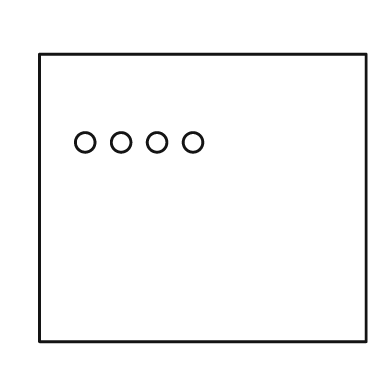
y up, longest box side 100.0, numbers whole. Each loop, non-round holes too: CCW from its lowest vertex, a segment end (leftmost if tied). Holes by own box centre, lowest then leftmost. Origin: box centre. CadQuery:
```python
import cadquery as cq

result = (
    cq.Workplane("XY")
    .moveTo(-50.0, -44.0)
    .lineTo(50.0, -44.0)
    .lineTo(50.0, 44.0)
    .lineTo(-50.0, 44.0)
    .close()
    .moveTo(-36.0, 17.0)
    .circle(3.0)
    .moveTo(-25.0, 17.0)
    .circle(3.0)
    .moveTo(-14.0, 17.0)
    .circle(3.0)
    .moveTo(-3.0, 17.0)
    .circle(3.0)
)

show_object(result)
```